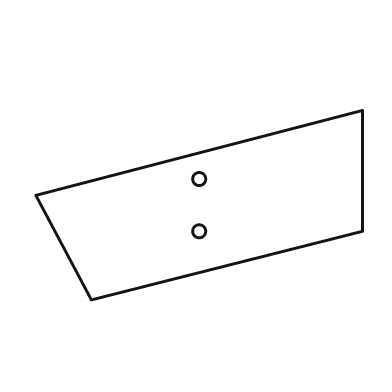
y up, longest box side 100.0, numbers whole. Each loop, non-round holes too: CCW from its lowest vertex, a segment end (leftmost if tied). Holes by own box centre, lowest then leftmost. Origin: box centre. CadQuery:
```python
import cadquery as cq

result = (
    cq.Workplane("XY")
    .moveTo(-33.0, -29.0)
    .lineTo(50.0, -8.0)
    .lineTo(50.0, 29.0)
    .lineTo(-50.0, 3.0)
    .close()
    .moveTo(0.0, -8.0)
    .circle(2.0)
    .moveTo(0.0, 8.0)
    .circle(2.0)
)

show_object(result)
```